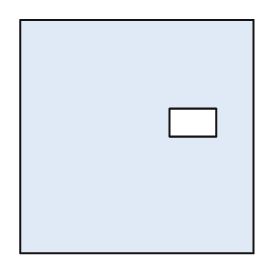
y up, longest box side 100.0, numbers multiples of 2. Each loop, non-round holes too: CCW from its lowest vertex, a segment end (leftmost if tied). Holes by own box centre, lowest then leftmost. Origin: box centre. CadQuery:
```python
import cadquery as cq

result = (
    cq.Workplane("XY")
    .moveTo(-50.0, -50.0)
    .lineTo(50.0, -50.0)
    .lineTo(50.0, 50.0)
    .lineTo(-50.0, 50.0)
    .close()
    .moveTo(14.0, 0.0)
    .lineTo(34.0, 0.0)
    .lineTo(34.0, 12.0)
    .lineTo(14.0, 12.0)
    .close()
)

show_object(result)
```